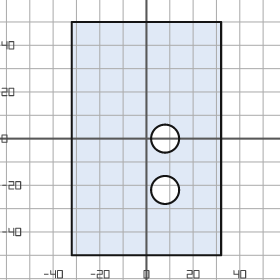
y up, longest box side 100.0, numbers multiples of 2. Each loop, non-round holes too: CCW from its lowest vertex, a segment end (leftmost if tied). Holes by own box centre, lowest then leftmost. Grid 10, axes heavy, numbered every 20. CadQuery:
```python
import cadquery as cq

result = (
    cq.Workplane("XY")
    .moveTo(-32.0, -50.0)
    .lineTo(32.0, -50.0)
    .lineTo(32.0, 50.0)
    .lineTo(-32.0, 50.0)
    .close()
    .moveTo(8.0, -22.0)
    .circle(6.0)
    .moveTo(8.0, 0.0)
    .circle(6.0)
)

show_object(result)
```